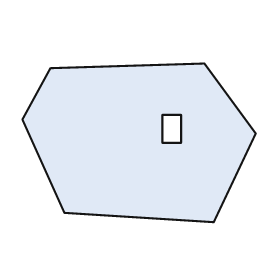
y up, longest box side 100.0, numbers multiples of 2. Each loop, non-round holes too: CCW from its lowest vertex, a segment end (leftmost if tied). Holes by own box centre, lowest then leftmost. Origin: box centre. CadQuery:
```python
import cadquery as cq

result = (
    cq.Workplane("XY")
    .moveTo(32.0, -34.0)
    .lineTo(50.0, 4.0)
    .lineTo(28.0, 34.0)
    .lineTo(-38.0, 32.0)
    .lineTo(-50.0, 10.0)
    .lineTo(-32.0, -30.0)
    .close()
    .moveTo(10.0, 0.0)
    .lineTo(18.0, 0.0)
    .lineTo(18.0, 12.0)
    .lineTo(10.0, 12.0)
    .close()
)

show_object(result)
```